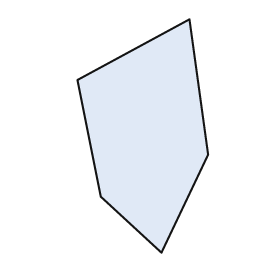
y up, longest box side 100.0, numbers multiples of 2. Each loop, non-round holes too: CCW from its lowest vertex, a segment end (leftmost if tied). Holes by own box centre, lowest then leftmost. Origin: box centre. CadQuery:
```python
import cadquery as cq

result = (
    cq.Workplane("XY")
    .moveTo(8.0, -50.0)
    .lineTo(28.0, -8.0)
    .lineTo(20.0, 50.0)
    .lineTo(-28.0, 24.0)
    .lineTo(-18.0, -26.0)
    .close()
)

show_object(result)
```